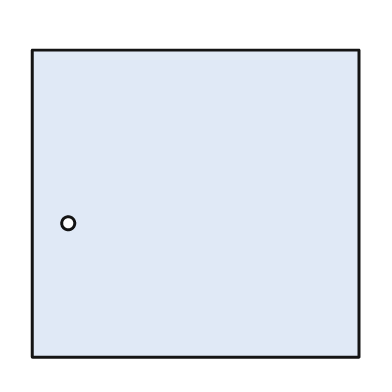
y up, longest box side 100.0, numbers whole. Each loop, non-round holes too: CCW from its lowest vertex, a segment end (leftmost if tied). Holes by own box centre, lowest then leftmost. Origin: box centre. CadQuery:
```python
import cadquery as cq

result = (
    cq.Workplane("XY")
    .moveTo(-50.0, -47.0)
    .lineTo(50.0, -47.0)
    .lineTo(50.0, 47.0)
    .lineTo(-50.0, 47.0)
    .close()
    .moveTo(-39.0, -6.0)
    .circle(2.0)
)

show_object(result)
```